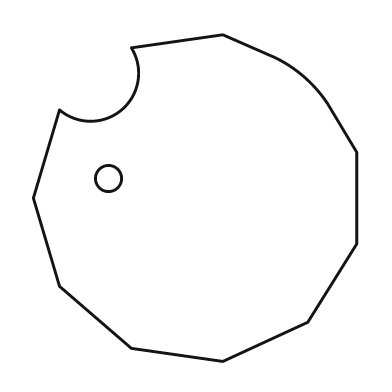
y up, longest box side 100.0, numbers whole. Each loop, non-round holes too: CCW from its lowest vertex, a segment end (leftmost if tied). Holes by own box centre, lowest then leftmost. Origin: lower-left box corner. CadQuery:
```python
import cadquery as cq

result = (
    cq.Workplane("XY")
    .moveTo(58.0, 0.0)
    .lineTo(84.0, 12.0)
    .lineTo(99.0, 36.0)
    .lineTo(99.0, 64.0)
    .lineTo(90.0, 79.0)
    .threePointArc((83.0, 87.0), (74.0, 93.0))
    .lineTo(58.0, 100.0)
    .lineTo(30.0, 96.0)
    .threePointArc((27.0, 77.0), (8.0, 77.0))
    .lineTo(0.0, 50.0)
    .lineTo(8.0, 23.0)
    .lineTo(30.0, 4.0)
    .close()
    .moveTo(23.0, 56.0)
    .circle(4.0)
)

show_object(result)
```